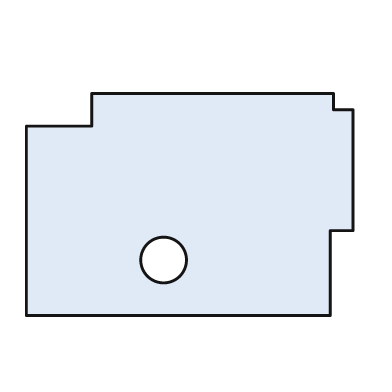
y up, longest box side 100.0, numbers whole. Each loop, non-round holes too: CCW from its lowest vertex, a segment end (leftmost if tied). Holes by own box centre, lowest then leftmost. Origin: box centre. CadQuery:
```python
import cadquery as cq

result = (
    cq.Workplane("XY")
    .moveTo(-50.0, -34.0)
    .lineTo(43.0, -34.0)
    .lineTo(43.0, -8.0)
    .lineTo(50.0, -8.0)
    .lineTo(50.0, 29.0)
    .lineTo(44.0, 29.0)
    .lineTo(44.0, 34.0)
    .lineTo(-30.0, 34.0)
    .lineTo(-30.0, 24.0)
    .lineTo(-50.0, 24.0)
    .close()
    .moveTo(-8.0, -17.0)
    .circle(7.0)
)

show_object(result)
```